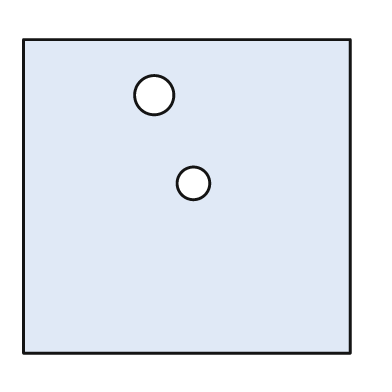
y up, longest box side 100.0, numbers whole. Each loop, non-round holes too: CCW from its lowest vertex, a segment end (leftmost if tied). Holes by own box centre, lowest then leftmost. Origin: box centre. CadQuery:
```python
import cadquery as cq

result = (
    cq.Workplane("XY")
    .moveTo(-50.0, -48.0)
    .lineTo(50.0, -48.0)
    .lineTo(50.0, 48.0)
    .lineTo(-50.0, 48.0)
    .close()
    .moveTo(2.0, 4.0)
    .circle(5.0)
    .moveTo(-10.0, 31.0)
    .circle(6.0)
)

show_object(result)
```